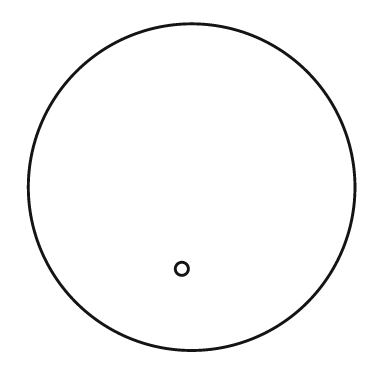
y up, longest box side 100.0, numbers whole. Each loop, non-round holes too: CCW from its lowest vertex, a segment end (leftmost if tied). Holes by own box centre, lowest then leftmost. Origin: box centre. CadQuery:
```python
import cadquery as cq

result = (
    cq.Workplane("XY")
    .moveTo(0.0, 0.0)
    .circle(50.0)
    .moveTo(-3.0, -25.0)
    .circle(2.0)
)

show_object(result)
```